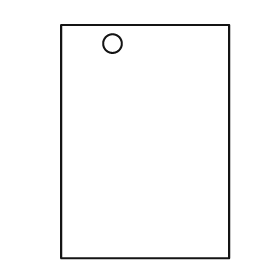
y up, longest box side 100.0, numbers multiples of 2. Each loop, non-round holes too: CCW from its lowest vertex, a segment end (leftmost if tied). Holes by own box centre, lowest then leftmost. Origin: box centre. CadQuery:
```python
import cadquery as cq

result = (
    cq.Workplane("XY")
    .moveTo(-36.0, -50.0)
    .lineTo(36.0, -50.0)
    .lineTo(36.0, 50.0)
    .lineTo(-36.0, 50.0)
    .close()
    .moveTo(-14.0, 42.0)
    .circle(4.0)
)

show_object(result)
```